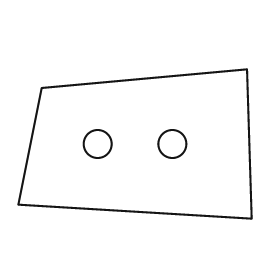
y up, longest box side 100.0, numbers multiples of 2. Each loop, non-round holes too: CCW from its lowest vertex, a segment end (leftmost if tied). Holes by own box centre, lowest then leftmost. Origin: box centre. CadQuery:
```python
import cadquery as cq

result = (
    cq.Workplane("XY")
    .moveTo(50.0, -32.0)
    .lineTo(48.0, 32.0)
    .lineTo(-40.0, 24.0)
    .lineTo(-50.0, -26.0)
    .close()
    .moveTo(-16.0, 0.0)
    .circle(6.0)
    .moveTo(16.0, 0.0)
    .circle(6.0)
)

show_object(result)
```